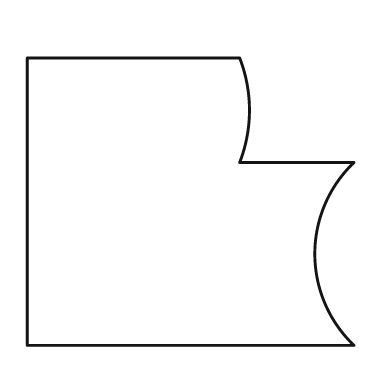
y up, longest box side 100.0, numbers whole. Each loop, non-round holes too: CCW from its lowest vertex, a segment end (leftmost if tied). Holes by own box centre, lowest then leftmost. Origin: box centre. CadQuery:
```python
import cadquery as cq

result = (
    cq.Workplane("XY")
    .moveTo(-50.0, -44.0)
    .lineTo(50.0, -44.0)
    .threePointArc((38.0, -16.0), (50.0, 12.0))
    .lineTo(15.0, 12.0)
    .threePointArc((18.0, 28.0), (15.0, 44.0))
    .lineTo(-50.0, 44.0)
    .close()
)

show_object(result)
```